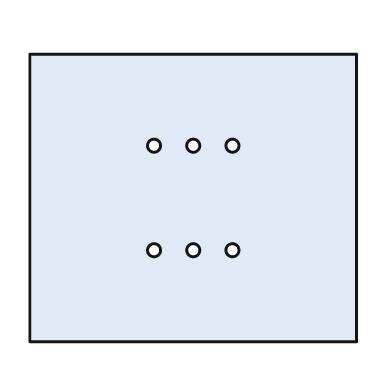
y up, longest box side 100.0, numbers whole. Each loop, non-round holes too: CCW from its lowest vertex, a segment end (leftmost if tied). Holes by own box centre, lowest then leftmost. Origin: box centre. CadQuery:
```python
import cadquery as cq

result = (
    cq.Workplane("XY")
    .moveTo(-50.0, -44.0)
    .lineTo(50.0, -44.0)
    .lineTo(50.0, 44.0)
    .lineTo(-50.0, 44.0)
    .close()
    .moveTo(-12.0, -16.0)
    .circle(2.0)
    .moveTo(0.0, -16.0)
    .circle(2.0)
    .moveTo(12.0, -16.0)
    .circle(2.0)
    .moveTo(-12.0, 16.0)
    .circle(2.0)
    .moveTo(0.0, 16.0)
    .circle(2.0)
    .moveTo(12.0, 16.0)
    .circle(2.0)
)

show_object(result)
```